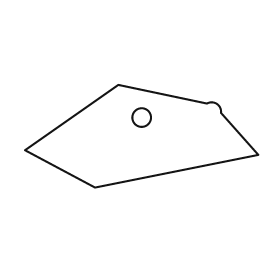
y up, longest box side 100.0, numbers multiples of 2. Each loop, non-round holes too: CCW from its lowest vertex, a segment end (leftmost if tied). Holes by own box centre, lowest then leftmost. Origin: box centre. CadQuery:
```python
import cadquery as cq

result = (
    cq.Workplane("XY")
    .moveTo(-20.0, -22.0)
    .lineTo(50.0, -8.0)
    .lineTo(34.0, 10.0)
    .threePointArc((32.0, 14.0), (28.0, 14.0))
    .lineTo(-10.0, 22.0)
    .lineTo(-50.0, -6.0)
    .close()
    .moveTo(0.0, 8.0)
    .circle(4.0)
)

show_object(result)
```